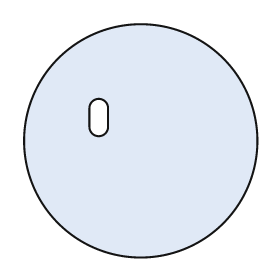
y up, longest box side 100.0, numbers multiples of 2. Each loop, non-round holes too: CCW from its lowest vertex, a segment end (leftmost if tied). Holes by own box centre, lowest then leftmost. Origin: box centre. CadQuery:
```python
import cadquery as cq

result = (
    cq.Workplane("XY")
    .moveTo(0.0, 0.0)
    .circle(50.0)
    .moveTo(-22.0, 6.0)
    .threePointArc((-18.0, 2.0), (-14.0, 6.0))
    .lineTo(-14.0, 14.0)
    .threePointArc((-18.0, 18.0), (-22.0, 14.0))
    .close()
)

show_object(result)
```